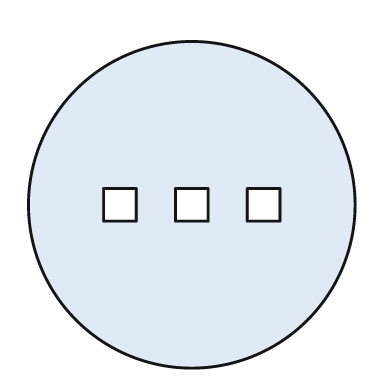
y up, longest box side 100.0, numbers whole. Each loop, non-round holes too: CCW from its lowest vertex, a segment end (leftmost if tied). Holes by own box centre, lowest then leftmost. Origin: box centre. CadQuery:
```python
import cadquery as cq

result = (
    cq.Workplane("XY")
    .moveTo(0.0, 0.0)
    .circle(50.0)
    .moveTo(-27.0, -5.0)
    .lineTo(-17.0, -5.0)
    .lineTo(-17.0, 5.0)
    .lineTo(-27.0, 5.0)
    .close()
    .moveTo(-5.0, -5.0)
    .lineTo(5.0, -5.0)
    .lineTo(5.0, 5.0)
    .lineTo(-5.0, 5.0)
    .close()
    .moveTo(17.0, -5.0)
    .lineTo(27.0, -5.0)
    .lineTo(27.0, 5.0)
    .lineTo(17.0, 5.0)
    .close()
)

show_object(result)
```